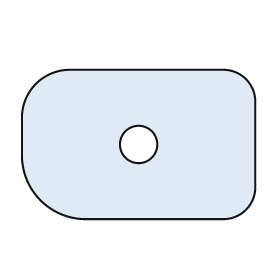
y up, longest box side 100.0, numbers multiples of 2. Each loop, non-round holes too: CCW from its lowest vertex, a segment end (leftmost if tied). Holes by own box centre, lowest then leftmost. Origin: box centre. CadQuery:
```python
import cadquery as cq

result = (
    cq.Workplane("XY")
    .moveTo(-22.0, -32.0)
    .lineTo(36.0, -32.0)
    .threePointArc((46.0, -28.0), (50.0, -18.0))
    .lineTo(50.0, 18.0)
    .threePointArc((46.0, 28.0), (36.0, 32.0))
    .lineTo(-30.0, 32.0)
    .threePointArc((-44.0, 26.0), (-50.0, 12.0))
    .lineTo(-50.0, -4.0)
    .threePointArc((-42.0, -24.0), (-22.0, -32.0))
    .close()
    .moveTo(0.0, 0.0)
    .circle(8.0)
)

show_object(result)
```